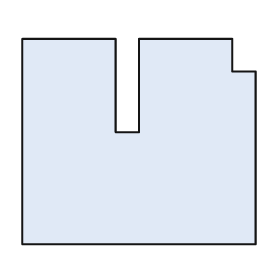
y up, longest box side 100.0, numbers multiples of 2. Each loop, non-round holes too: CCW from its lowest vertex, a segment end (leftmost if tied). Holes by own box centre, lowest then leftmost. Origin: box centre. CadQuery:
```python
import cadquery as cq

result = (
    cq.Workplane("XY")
    .moveTo(-50.0, -44.0)
    .lineTo(50.0, -44.0)
    .lineTo(50.0, 30.0)
    .lineTo(40.0, 30.0)
    .lineTo(40.0, 44.0)
    .lineTo(0.0, 44.0)
    .lineTo(0.0, 4.0)
    .lineTo(-10.0, 4.0)
    .lineTo(-10.0, 44.0)
    .lineTo(-50.0, 44.0)
    .close()
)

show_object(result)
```